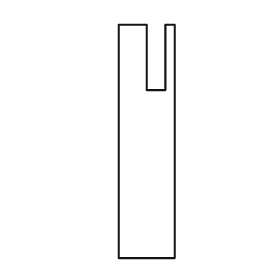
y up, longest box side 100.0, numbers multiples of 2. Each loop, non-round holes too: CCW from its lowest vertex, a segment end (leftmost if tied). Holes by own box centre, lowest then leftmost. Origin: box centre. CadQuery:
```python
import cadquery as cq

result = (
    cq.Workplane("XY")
    .moveTo(-12.0, -50.0)
    .lineTo(12.0, -50.0)
    .lineTo(12.0, 50.0)
    .lineTo(8.0, 50.0)
    .lineTo(8.0, 22.0)
    .lineTo(0.0, 22.0)
    .lineTo(0.0, 50.0)
    .lineTo(-12.0, 50.0)
    .close()
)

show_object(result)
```